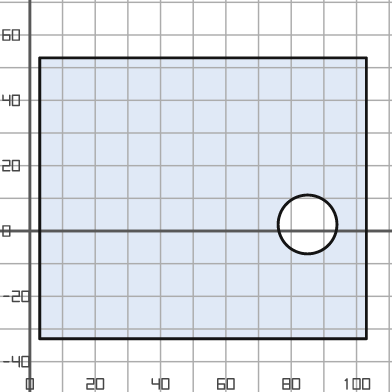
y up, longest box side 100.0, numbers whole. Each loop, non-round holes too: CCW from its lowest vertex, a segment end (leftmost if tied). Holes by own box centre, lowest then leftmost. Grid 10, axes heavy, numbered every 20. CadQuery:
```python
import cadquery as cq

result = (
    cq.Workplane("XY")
    .moveTo(3.0, -33.0)
    .lineTo(103.0, -33.0)
    .lineTo(103.0, 53.0)
    .lineTo(3.0, 53.0)
    .close()
    .moveTo(85.0, 2.0)
    .circle(9.0)
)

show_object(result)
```